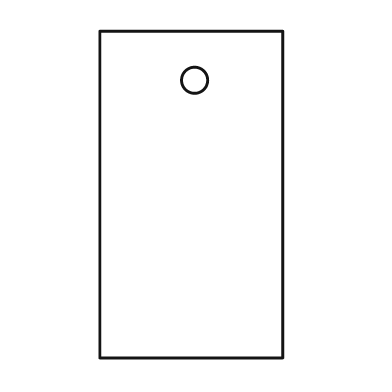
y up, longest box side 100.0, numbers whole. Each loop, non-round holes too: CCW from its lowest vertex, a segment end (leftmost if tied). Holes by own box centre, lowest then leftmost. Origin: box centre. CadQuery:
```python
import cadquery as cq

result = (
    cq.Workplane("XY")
    .moveTo(-28.0, -50.0)
    .lineTo(28.0, -50.0)
    .lineTo(28.0, 50.0)
    .lineTo(-28.0, 50.0)
    .close()
    .moveTo(1.0, 35.0)
    .circle(4.0)
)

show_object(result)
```